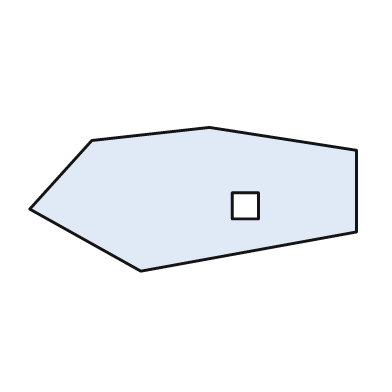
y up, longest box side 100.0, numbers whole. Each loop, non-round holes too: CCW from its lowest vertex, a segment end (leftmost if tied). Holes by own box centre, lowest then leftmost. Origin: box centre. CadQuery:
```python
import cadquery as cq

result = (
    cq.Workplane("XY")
    .moveTo(-16.0, -22.0)
    .lineTo(50.0, -10.0)
    .lineTo(50.0, 15.0)
    .lineTo(5.0, 22.0)
    .lineTo(-31.0, 18.0)
    .lineTo(-50.0, -3.0)
    .close()
    .moveTo(12.0, -6.0)
    .lineTo(20.0, -6.0)
    .lineTo(20.0, 2.0)
    .lineTo(12.0, 2.0)
    .close()
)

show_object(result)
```